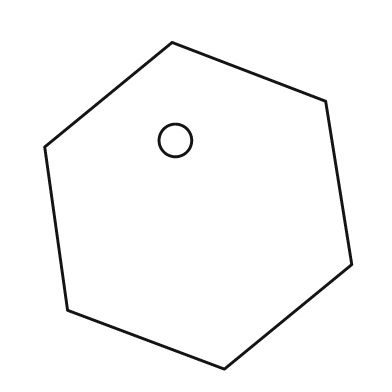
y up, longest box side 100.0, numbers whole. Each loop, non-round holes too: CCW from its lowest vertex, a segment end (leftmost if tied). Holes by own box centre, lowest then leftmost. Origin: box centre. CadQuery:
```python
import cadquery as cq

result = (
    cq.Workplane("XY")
    .moveTo(8.0, -50.0)
    .lineTo(47.0, -18.0)
    .lineTo(39.0, 32.0)
    .lineTo(-8.0, 50.0)
    .lineTo(-47.0, 18.0)
    .lineTo(-40.0, -32.0)
    .close()
    .moveTo(-7.0, 20.0)
    .circle(5.0)
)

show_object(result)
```